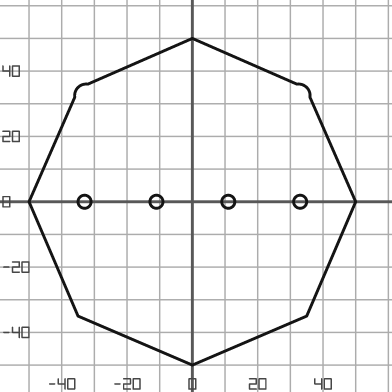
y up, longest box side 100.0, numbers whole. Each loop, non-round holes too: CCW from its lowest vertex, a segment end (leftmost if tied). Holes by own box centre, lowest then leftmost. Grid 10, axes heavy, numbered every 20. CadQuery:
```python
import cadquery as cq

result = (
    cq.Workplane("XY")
    .moveTo(0.0, -50.0)
    .lineTo(35.0, -35.0)
    .lineTo(50.0, 0.0)
    .lineTo(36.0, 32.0)
    .threePointArc((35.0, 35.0), (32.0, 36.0))
    .lineTo(0.0, 50.0)
    .lineTo(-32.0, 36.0)
    .threePointArc((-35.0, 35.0), (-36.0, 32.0))
    .lineTo(-50.0, 0.0)
    .lineTo(-35.0, -35.0)
    .close()
    .moveTo(-33.0, 0.0)
    .circle(2.0)
    .moveTo(-11.0, 0.0)
    .circle(2.0)
    .moveTo(11.0, 0.0)
    .circle(2.0)
    .moveTo(33.0, 0.0)
    .circle(2.0)
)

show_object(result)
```